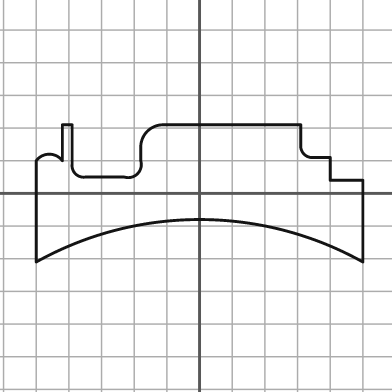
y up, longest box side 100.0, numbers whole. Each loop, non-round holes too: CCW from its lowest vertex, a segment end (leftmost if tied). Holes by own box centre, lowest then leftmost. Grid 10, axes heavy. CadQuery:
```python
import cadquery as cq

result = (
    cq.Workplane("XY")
    .moveTo(-50.0, -21.0)
    .threePointArc((0.0, -8.0), (50.0, -21.0))
    .lineTo(50.0, 4.0)
    .lineTo(40.0, 4.0)
    .lineTo(40.0, 11.0)
    .lineTo(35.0, 11.0)
    .threePointArc((32.0, 12.0), (31.0, 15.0))
    .lineTo(31.0, 21.0)
    .lineTo(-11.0, 21.0)
    .threePointArc((-16.0, 19.0), (-18.0, 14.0))
    .lineTo(-18.0, 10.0)
    .threePointArc((-19.0, 6.0), (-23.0, 5.0))
    .lineTo(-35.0, 5.0)
    .threePointArc((-38.0, 6.0), (-39.0, 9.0))
    .lineTo(-39.0, 21.0)
    .lineTo(-42.0, 21.0)
    .lineTo(-42.0, 10.0)
    .threePointArc((-46.0, 12.0), (-50.0, 10.0))
    .close()
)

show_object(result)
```